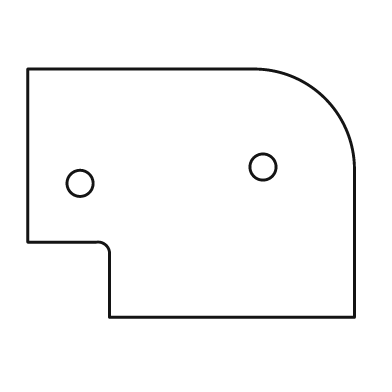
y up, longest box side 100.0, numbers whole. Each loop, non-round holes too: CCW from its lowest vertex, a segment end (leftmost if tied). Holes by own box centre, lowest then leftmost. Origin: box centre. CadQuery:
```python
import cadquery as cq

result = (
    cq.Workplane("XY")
    .moveTo(-25.0, -38.0)
    .lineTo(50.0, -38.0)
    .lineTo(50.0, 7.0)
    .threePointArc((41.0, 29.0), (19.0, 38.0))
    .lineTo(-50.0, 38.0)
    .lineTo(-50.0, -15.0)
    .lineTo(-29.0, -15.0)
    .threePointArc((-26.0, -16.0), (-25.0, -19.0))
    .close()
    .moveTo(-34.0, 3.0)
    .circle(4.0)
    .moveTo(22.0, 8.0)
    .circle(4.0)
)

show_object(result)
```